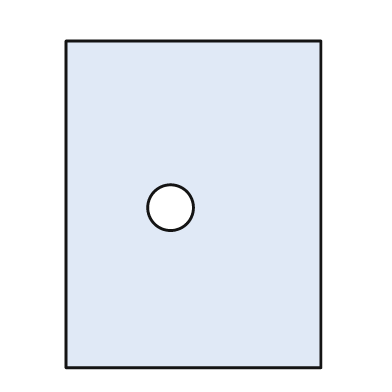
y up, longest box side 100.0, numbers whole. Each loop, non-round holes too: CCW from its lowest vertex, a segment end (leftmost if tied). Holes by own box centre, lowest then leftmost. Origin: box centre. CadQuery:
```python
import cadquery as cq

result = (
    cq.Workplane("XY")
    .moveTo(-39.0, -50.0)
    .lineTo(39.0, -50.0)
    .lineTo(39.0, 50.0)
    .lineTo(-39.0, 50.0)
    .close()
    .moveTo(-7.0, -1.0)
    .circle(7.0)
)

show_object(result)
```